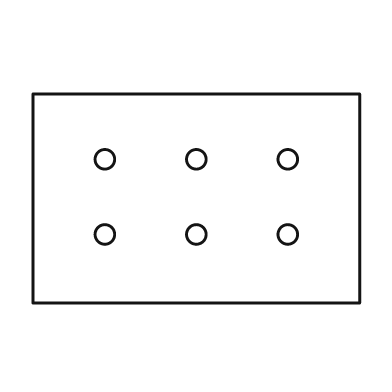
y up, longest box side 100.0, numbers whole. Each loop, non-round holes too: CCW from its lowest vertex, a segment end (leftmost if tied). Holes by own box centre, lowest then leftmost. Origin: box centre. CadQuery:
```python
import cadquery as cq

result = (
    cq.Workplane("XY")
    .moveTo(-50.0, -32.0)
    .lineTo(50.0, -32.0)
    .lineTo(50.0, 32.0)
    .lineTo(-50.0, 32.0)
    .close()
    .moveTo(-28.0, -11.0)
    .circle(3.0)
    .moveTo(0.0, -11.0)
    .circle(3.0)
    .moveTo(28.0, -11.0)
    .circle(3.0)
    .moveTo(-28.0, 12.0)
    .circle(3.0)
    .moveTo(0.0, 12.0)
    .circle(3.0)
    .moveTo(28.0, 12.0)
    .circle(3.0)
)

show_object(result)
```